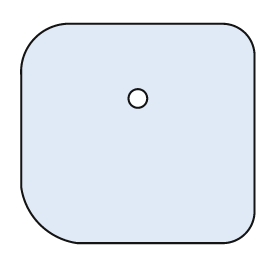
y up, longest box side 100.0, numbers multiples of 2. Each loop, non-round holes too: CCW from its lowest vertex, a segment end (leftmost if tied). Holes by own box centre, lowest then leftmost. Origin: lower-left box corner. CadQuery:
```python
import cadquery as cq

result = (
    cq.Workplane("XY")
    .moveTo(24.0, 0.0)
    .lineTo(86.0, 0.0)
    .threePointArc((96.0, 4.0), (100.0, 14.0))
    .lineTo(100.0, 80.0)
    .threePointArc((96.0, 90.0), (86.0, 94.0))
    .lineTo(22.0, 94.0)
    .threePointArc((6.0, 88.0), (0.0, 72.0))
    .lineTo(0.0, 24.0)
    .threePointArc((8.0, 8.0), (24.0, 0.0))
    .close()
    .moveTo(50.0, 62.0)
    .circle(4.0)
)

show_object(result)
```